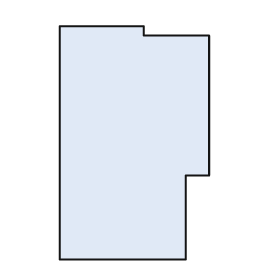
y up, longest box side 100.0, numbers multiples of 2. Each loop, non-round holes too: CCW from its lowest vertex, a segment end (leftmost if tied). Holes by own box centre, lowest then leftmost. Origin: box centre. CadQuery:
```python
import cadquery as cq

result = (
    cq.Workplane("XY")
    .moveTo(-32.0, -50.0)
    .lineTo(22.0, -50.0)
    .lineTo(22.0, -14.0)
    .lineTo(32.0, -14.0)
    .lineTo(32.0, 46.0)
    .lineTo(4.0, 46.0)
    .lineTo(4.0, 50.0)
    .lineTo(-32.0, 50.0)
    .close()
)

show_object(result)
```